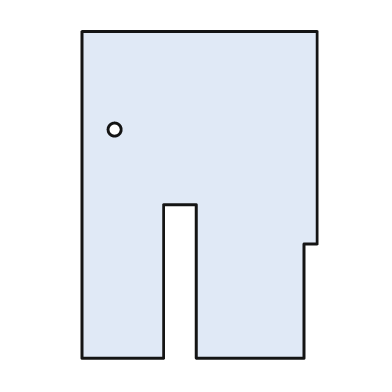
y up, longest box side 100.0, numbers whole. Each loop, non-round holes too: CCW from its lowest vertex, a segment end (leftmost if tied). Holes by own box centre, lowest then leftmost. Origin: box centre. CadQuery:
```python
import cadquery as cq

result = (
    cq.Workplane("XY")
    .moveTo(-36.0, -50.0)
    .lineTo(-11.0, -50.0)
    .lineTo(-11.0, -3.0)
    .lineTo(-1.0, -3.0)
    .lineTo(-1.0, -50.0)
    .lineTo(32.0, -50.0)
    .lineTo(32.0, -15.0)
    .lineTo(36.0, -15.0)
    .lineTo(36.0, 50.0)
    .lineTo(-36.0, 50.0)
    .close()
    .moveTo(-26.0, 20.0)
    .circle(2.0)
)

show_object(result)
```